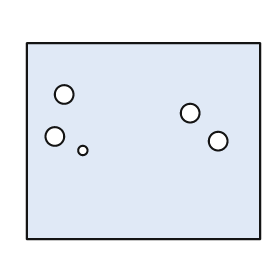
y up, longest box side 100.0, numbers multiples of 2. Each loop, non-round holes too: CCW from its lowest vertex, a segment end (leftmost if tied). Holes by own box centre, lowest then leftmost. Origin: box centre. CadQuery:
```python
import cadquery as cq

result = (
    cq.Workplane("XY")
    .moveTo(-50.0, -42.0)
    .lineTo(50.0, -42.0)
    .lineTo(50.0, 42.0)
    .lineTo(-50.0, 42.0)
    .close()
    .moveTo(-26.0, -4.0)
    .circle(2.0)
    .moveTo(32.0, 0.0)
    .circle(4.0)
    .moveTo(-38.0, 2.0)
    .circle(4.0)
    .moveTo(20.0, 12.0)
    .circle(4.0)
    .moveTo(-34.0, 20.0)
    .circle(4.0)
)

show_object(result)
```